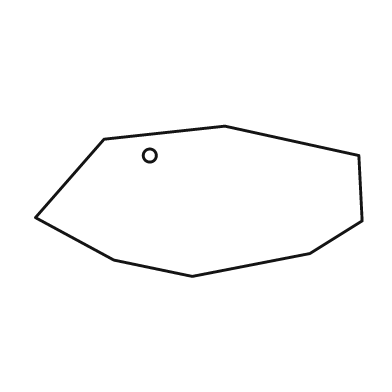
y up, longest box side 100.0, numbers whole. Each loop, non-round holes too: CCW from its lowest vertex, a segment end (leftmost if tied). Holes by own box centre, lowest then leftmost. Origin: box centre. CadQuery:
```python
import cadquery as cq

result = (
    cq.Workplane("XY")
    .moveTo(-2.0, -23.0)
    .lineTo(34.0, -16.0)
    .lineTo(50.0, -6.0)
    .lineTo(49.0, 14.0)
    .lineTo(8.0, 23.0)
    .lineTo(-29.0, 19.0)
    .lineTo(-50.0, -5.0)
    .lineTo(-26.0, -18.0)
    .close()
    .moveTo(-15.0, 14.0)
    .circle(2.0)
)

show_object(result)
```